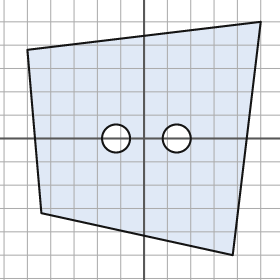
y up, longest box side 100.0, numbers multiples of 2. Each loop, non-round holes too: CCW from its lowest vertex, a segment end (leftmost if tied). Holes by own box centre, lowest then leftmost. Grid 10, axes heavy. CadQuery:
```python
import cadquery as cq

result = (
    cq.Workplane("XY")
    .moveTo(38.0, -50.0)
    .lineTo(50.0, 50.0)
    .lineTo(-50.0, 38.0)
    .lineTo(-44.0, -32.0)
    .close()
    .moveTo(-12.0, 0.0)
    .circle(6.0)
    .moveTo(14.0, 0.0)
    .circle(6.0)
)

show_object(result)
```